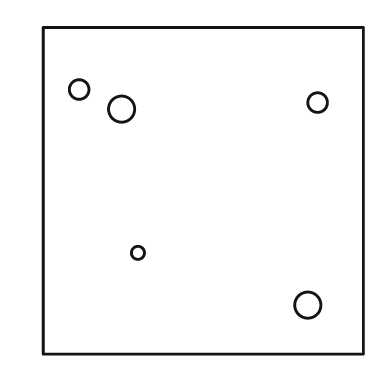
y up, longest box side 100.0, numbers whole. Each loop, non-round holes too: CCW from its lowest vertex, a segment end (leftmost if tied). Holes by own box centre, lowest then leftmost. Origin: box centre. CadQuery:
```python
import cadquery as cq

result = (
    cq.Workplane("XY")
    .moveTo(-49.0, -50.0)
    .lineTo(49.0, -50.0)
    .lineTo(49.0, 50.0)
    .lineTo(-49.0, 50.0)
    .close()
    .moveTo(32.0, -35.0)
    .circle(4.0)
    .moveTo(-20.0, -19.0)
    .circle(2.0)
    .moveTo(-25.0, 25.0)
    .circle(4.0)
    .moveTo(35.0, 27.0)
    .circle(3.0)
    .moveTo(-38.0, 31.0)
    .circle(3.0)
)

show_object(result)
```